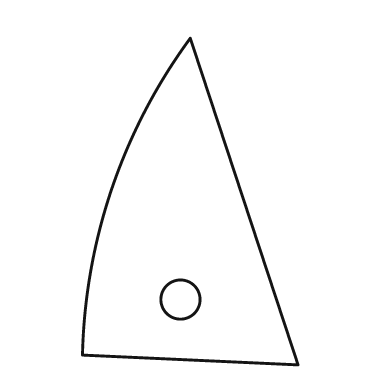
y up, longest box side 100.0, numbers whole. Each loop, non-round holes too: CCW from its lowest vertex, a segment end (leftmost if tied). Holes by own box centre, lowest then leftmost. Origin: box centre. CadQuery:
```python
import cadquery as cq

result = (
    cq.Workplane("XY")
    .moveTo(33.0, -50.0)
    .lineTo(0.0, 50.0)
    .threePointArc((-24.0, 4.0), (-33.0, -47.0))
    .close()
    .moveTo(-3.0, -30.0)
    .circle(6.0)
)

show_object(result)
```